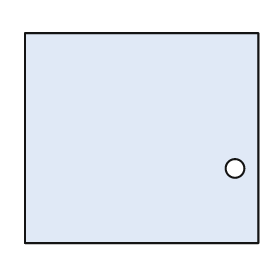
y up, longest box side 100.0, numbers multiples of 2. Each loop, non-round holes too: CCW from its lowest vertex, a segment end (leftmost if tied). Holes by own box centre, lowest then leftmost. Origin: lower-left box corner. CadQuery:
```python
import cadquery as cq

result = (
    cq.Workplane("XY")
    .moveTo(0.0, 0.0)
    .lineTo(100.0, 0.0)
    .lineTo(100.0, 90.0)
    .lineTo(0.0, 90.0)
    .close()
    .moveTo(90.0, 32.0)
    .circle(4.0)
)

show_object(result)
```